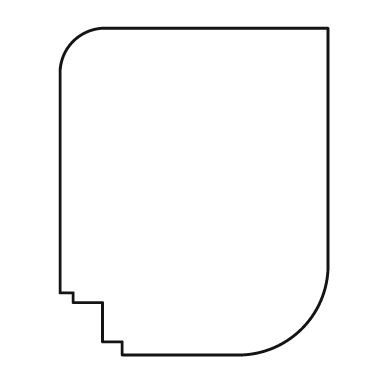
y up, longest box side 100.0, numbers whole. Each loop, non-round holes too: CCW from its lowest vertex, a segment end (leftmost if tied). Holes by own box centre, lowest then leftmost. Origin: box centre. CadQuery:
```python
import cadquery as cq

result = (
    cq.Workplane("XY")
    .moveTo(-22.0, -50.0)
    .lineTo(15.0, -50.0)
    .threePointArc((33.0, -42.0), (41.0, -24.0))
    .lineTo(41.0, 50.0)
    .lineTo(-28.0, 50.0)
    .threePointArc((-37.0, 46.0), (-41.0, 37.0))
    .lineTo(-41.0, -31.0)
    .lineTo(-37.0, -31.0)
    .lineTo(-37.0, -34.0)
    .lineTo(-28.0, -34.0)
    .lineTo(-28.0, -46.0)
    .lineTo(-22.0, -46.0)
    .close()
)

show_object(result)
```